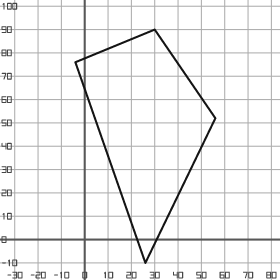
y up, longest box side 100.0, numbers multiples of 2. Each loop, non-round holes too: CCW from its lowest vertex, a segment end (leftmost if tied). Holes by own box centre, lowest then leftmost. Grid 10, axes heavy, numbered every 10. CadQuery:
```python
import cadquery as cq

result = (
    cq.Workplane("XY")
    .moveTo(26.0, -10.0)
    .lineTo(56.0, 52.0)
    .lineTo(30.0, 90.0)
    .lineTo(-4.0, 76.0)
    .close()
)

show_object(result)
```